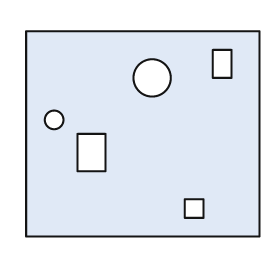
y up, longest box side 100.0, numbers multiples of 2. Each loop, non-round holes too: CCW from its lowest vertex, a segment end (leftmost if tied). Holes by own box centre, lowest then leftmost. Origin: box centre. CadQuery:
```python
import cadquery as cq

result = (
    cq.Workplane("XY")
    .moveTo(-50.0, -44.0)
    .lineTo(50.0, -44.0)
    .lineTo(50.0, 44.0)
    .lineTo(-50.0, 44.0)
    .close()
    .moveTo(18.0, -36.0)
    .lineTo(26.0, -36.0)
    .lineTo(26.0, -28.0)
    .lineTo(18.0, -28.0)
    .close()
    .moveTo(-28.0, -16.0)
    .lineTo(-16.0, -16.0)
    .lineTo(-16.0, 0.0)
    .lineTo(-28.0, 0.0)
    .close()
    .moveTo(-38.0, 6.0)
    .circle(4.0)
    .moveTo(4.0, 24.0)
    .circle(8.0)
    .moveTo(30.0, 24.0)
    .lineTo(38.0, 24.0)
    .lineTo(38.0, 36.0)
    .lineTo(30.0, 36.0)
    .close()
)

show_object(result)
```